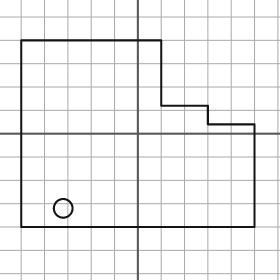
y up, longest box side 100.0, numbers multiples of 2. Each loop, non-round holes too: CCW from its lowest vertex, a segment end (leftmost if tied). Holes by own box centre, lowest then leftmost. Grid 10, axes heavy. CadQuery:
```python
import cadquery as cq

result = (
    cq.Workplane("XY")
    .moveTo(-50.0, -40.0)
    .lineTo(50.0, -40.0)
    .lineTo(50.0, 4.0)
    .lineTo(30.0, 4.0)
    .lineTo(30.0, 12.0)
    .lineTo(10.0, 12.0)
    .lineTo(10.0, 40.0)
    .lineTo(-50.0, 40.0)
    .close()
    .moveTo(-32.0, -32.0)
    .circle(4.0)
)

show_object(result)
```